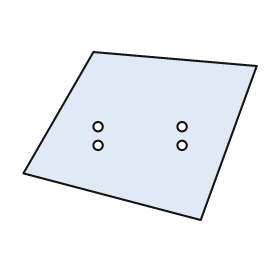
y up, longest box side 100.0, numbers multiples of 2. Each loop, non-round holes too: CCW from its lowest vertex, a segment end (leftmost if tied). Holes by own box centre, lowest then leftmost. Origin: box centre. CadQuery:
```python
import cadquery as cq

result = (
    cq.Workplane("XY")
    .moveTo(26.0, -36.0)
    .lineTo(50.0, 30.0)
    .lineTo(-20.0, 36.0)
    .lineTo(-50.0, -16.0)
    .close()
    .moveTo(-18.0, -4.0)
    .circle(2.0)
    .moveTo(18.0, -4.0)
    .circle(2.0)
    .moveTo(-18.0, 4.0)
    .circle(2.0)
    .moveTo(18.0, 4.0)
    .circle(2.0)
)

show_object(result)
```